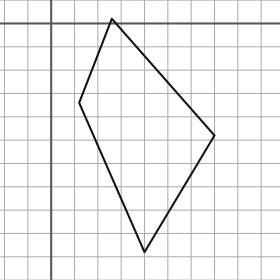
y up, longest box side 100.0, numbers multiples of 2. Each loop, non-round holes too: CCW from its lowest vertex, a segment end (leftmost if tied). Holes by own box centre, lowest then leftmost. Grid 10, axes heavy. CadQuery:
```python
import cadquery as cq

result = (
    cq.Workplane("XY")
    .moveTo(40.0, -98.0)
    .lineTo(70.0, -48.0)
    .lineTo(26.0, 2.0)
    .lineTo(12.0, -34.0)
    .close()
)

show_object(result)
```